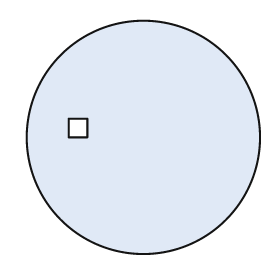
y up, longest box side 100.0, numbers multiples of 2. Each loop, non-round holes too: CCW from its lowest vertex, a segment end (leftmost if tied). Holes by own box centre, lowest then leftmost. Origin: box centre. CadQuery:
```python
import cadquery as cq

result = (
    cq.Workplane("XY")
    .moveTo(0.0, 0.0)
    .circle(50.0)
    .moveTo(-32.0, 0.0)
    .lineTo(-24.0, 0.0)
    .lineTo(-24.0, 8.0)
    .lineTo(-32.0, 8.0)
    .close()
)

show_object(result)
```